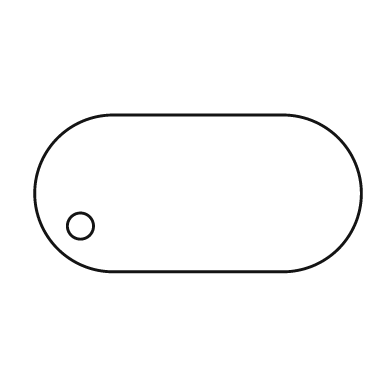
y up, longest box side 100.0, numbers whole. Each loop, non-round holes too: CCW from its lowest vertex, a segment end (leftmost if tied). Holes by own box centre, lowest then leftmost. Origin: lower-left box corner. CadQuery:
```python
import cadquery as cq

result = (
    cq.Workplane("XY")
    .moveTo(24.0, 0.0)
    .lineTo(76.0, 0.0)
    .threePointArc((100.0, 24.0), (76.0, 48.0))
    .lineTo(24.0, 48.0)
    .threePointArc((0.0, 24.0), (24.0, 0.0))
    .close()
    .moveTo(14.0, 14.0)
    .circle(4.0)
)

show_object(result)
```